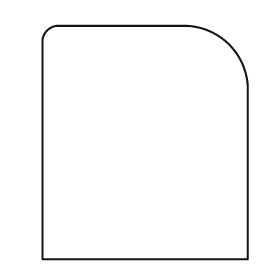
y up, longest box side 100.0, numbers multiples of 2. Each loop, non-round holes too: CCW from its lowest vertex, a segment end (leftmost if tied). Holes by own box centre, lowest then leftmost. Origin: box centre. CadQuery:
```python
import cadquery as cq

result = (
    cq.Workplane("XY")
    .moveTo(-44.0, -50.0)
    .lineTo(44.0, -50.0)
    .lineTo(44.0, 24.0)
    .threePointArc((36.0, 42.0), (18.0, 50.0))
    .lineTo(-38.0, 50.0)
    .threePointArc((-42.0, 48.0), (-44.0, 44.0))
    .close()
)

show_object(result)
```